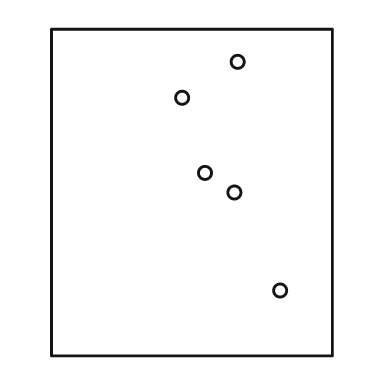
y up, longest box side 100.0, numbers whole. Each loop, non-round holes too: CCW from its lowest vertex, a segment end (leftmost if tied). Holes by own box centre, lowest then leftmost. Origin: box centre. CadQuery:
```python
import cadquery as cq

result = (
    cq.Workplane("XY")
    .moveTo(-43.0, -50.0)
    .lineTo(43.0, -50.0)
    .lineTo(43.0, 50.0)
    .lineTo(-43.0, 50.0)
    .close()
    .moveTo(27.0, -30.0)
    .circle(2.0)
    .moveTo(13.0, 0.0)
    .circle(2.0)
    .moveTo(4.0, 6.0)
    .circle(2.0)
    .moveTo(-3.0, 29.0)
    .circle(2.0)
    .moveTo(14.0, 40.0)
    .circle(2.0)
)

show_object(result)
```